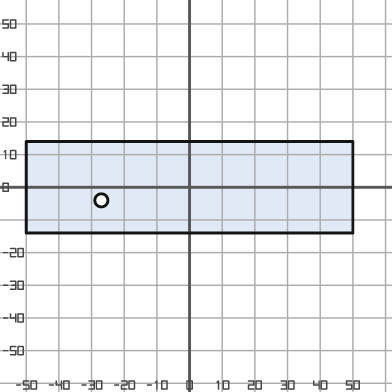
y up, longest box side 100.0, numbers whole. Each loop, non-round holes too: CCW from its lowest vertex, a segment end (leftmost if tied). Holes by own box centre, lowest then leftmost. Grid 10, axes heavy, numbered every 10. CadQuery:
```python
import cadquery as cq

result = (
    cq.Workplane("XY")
    .moveTo(-50.0, -14.0)
    .lineTo(50.0, -14.0)
    .lineTo(50.0, 14.0)
    .lineTo(-50.0, 14.0)
    .close()
    .moveTo(-27.0, -4.0)
    .circle(2.0)
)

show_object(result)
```